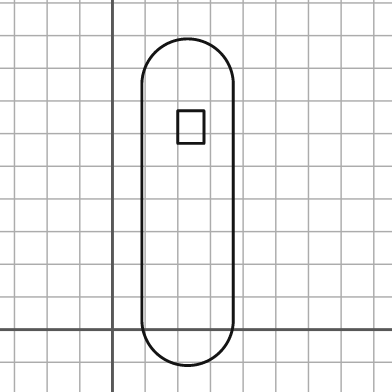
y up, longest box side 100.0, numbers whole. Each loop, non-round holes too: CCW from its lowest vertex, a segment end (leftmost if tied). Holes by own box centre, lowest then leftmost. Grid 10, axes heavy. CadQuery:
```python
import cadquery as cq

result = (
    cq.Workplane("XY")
    .moveTo(9.0, 3.0)
    .threePointArc((23.0, -11.0), (37.0, 3.0))
    .lineTo(37.0, 75.0)
    .threePointArc((23.0, 89.0), (9.0, 75.0))
    .close()
    .moveTo(20.0, 57.0)
    .lineTo(28.0, 57.0)
    .lineTo(28.0, 67.0)
    .lineTo(20.0, 67.0)
    .close()
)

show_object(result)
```